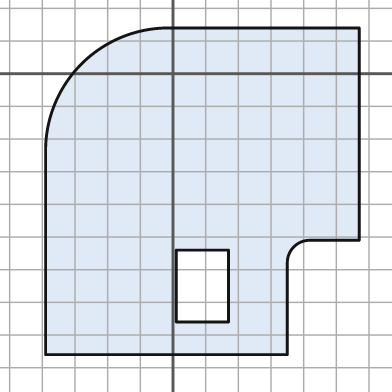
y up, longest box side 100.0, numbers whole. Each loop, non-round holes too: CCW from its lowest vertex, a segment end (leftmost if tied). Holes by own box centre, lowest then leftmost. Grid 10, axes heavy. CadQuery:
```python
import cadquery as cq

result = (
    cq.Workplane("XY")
    .moveTo(-39.0, -86.0)
    .lineTo(35.0, -86.0)
    .lineTo(35.0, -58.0)
    .threePointArc((37.0, -53.0), (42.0, -51.0))
    .lineTo(57.0, -51.0)
    .lineTo(57.0, 14.0)
    .lineTo(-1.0, 14.0)
    .threePointArc((-28.0, 3.0), (-39.0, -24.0))
    .close()
    .moveTo(1.0, -76.0)
    .lineTo(17.0, -76.0)
    .lineTo(17.0, -54.0)
    .lineTo(1.0, -54.0)
    .close()
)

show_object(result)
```